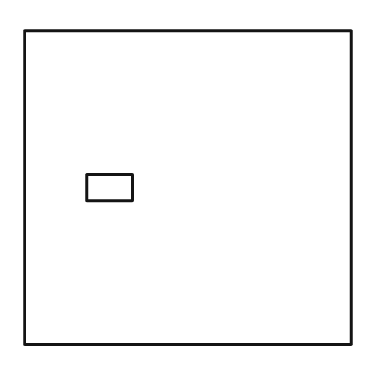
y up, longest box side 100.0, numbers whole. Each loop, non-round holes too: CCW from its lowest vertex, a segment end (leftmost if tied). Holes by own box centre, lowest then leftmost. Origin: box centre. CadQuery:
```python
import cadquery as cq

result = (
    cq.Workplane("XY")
    .moveTo(-50.0, -48.0)
    .lineTo(50.0, -48.0)
    .lineTo(50.0, 48.0)
    .lineTo(-50.0, 48.0)
    .close()
    .moveTo(-31.0, -4.0)
    .lineTo(-17.0, -4.0)
    .lineTo(-17.0, 4.0)
    .lineTo(-31.0, 4.0)
    .close()
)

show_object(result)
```